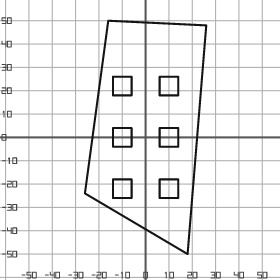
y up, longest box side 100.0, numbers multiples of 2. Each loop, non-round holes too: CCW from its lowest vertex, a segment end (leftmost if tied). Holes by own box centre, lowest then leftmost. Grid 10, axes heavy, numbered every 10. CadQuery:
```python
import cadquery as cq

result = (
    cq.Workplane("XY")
    .moveTo(18.0, -50.0)
    .lineTo(26.0, 48.0)
    .lineTo(-16.0, 50.0)
    .lineTo(-26.0, -24.0)
    .close()
    .moveTo(-14.0, -26.0)
    .lineTo(-6.0, -26.0)
    .lineTo(-6.0, -18.0)
    .lineTo(-14.0, -18.0)
    .close()
    .moveTo(6.0, -26.0)
    .lineTo(14.0, -26.0)
    .lineTo(14.0, -18.0)
    .lineTo(6.0, -18.0)
    .close()
    .moveTo(-14.0, -4.0)
    .lineTo(-6.0, -4.0)
    .lineTo(-6.0, 4.0)
    .lineTo(-14.0, 4.0)
    .close()
    .moveTo(6.0, -4.0)
    .lineTo(14.0, -4.0)
    .lineTo(14.0, 4.0)
    .lineTo(6.0, 4.0)
    .close()
    .moveTo(-14.0, 18.0)
    .lineTo(-6.0, 18.0)
    .lineTo(-6.0, 26.0)
    .lineTo(-14.0, 26.0)
    .close()
    .moveTo(6.0, 18.0)
    .lineTo(14.0, 18.0)
    .lineTo(14.0, 26.0)
    .lineTo(6.0, 26.0)
    .close()
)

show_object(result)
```